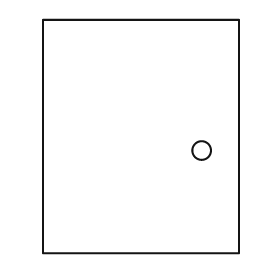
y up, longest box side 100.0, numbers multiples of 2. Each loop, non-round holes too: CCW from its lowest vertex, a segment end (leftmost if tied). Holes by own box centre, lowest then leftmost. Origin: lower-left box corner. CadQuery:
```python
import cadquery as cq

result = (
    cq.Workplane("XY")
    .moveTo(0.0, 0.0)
    .lineTo(84.0, 0.0)
    .lineTo(84.0, 100.0)
    .lineTo(0.0, 100.0)
    .close()
    .moveTo(68.0, 44.0)
    .circle(4.0)
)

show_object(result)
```